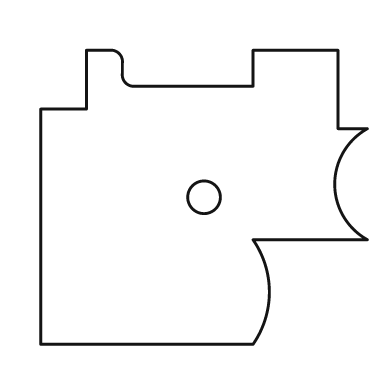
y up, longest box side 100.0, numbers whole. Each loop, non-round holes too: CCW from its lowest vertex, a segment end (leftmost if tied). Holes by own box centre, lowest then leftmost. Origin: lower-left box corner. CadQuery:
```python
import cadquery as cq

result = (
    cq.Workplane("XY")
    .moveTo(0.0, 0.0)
    .lineTo(65.0, 0.0)
    .threePointArc((70.0, 16.0), (65.0, 32.0))
    .lineTo(100.0, 32.0)
    .threePointArc((90.0, 49.0), (100.0, 66.0))
    .lineTo(91.0, 66.0)
    .lineTo(91.0, 90.0)
    .lineTo(65.0, 90.0)
    .lineTo(65.0, 79.0)
    .lineTo(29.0, 79.0)
    .threePointArc((26.0, 80.0), (25.0, 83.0))
    .lineTo(25.0, 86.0)
    .threePointArc((24.0, 89.0), (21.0, 90.0))
    .lineTo(14.0, 90.0)
    .lineTo(14.0, 72.0)
    .lineTo(0.0, 72.0)
    .close()
    .moveTo(50.0, 45.0)
    .circle(5.0)
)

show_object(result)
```